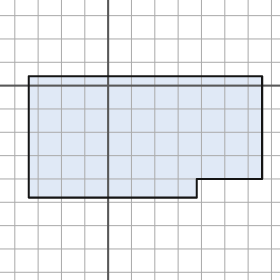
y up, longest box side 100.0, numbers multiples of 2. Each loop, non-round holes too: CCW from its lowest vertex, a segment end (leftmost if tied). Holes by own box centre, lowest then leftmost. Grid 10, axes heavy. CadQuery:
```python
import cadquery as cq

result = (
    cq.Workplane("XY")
    .moveTo(-34.0, -48.0)
    .lineTo(38.0, -48.0)
    .lineTo(38.0, -40.0)
    .lineTo(66.0, -40.0)
    .lineTo(66.0, 4.0)
    .lineTo(-34.0, 4.0)
    .close()
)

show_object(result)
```